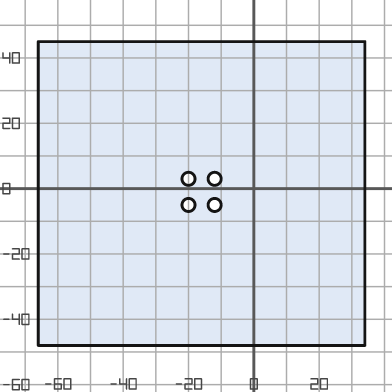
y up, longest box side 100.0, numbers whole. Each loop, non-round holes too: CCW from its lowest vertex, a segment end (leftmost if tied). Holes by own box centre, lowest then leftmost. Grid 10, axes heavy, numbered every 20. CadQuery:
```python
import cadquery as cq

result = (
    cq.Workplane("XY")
    .moveTo(-66.0, -48.0)
    .lineTo(34.0, -48.0)
    .lineTo(34.0, 45.0)
    .lineTo(-66.0, 45.0)
    .close()
    .moveTo(-20.0, -5.0)
    .circle(2.0)
    .moveTo(-12.0, -5.0)
    .circle(2.0)
    .moveTo(-20.0, 3.0)
    .circle(2.0)
    .moveTo(-12.0, 3.0)
    .circle(2.0)
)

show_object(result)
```